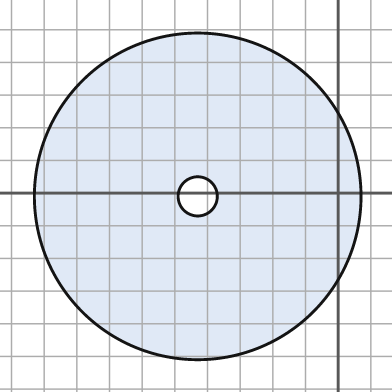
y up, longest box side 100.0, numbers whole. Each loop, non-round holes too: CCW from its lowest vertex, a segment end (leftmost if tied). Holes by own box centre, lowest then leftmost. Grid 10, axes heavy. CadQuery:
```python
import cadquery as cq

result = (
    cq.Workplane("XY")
    .moveTo(-43.0, -1.0)
    .circle(50.0)
    .moveTo(-43.0, -1.0)
    .circle(6.0)
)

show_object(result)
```